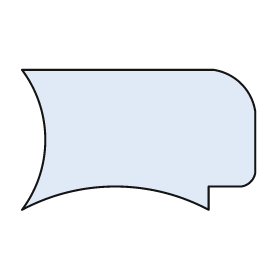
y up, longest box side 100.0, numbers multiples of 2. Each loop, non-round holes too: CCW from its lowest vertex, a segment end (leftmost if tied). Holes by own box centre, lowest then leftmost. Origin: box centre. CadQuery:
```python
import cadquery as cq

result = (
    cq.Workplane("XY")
    .moveTo(-50.0, -30.0)
    .threePointArc((-10.0, -20.0), (30.0, -30.0))
    .lineTo(30.0, -20.0)
    .lineTo(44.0, -20.0)
    .threePointArc((48.0, -18.0), (50.0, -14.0))
    .lineTo(50.0, 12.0)
    .threePointArc((44.0, 24.0), (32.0, 30.0))
    .lineTo(-50.0, 30.0)
    .threePointArc((-40.0, 0.0), (-50.0, -30.0))
    .close()
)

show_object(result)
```